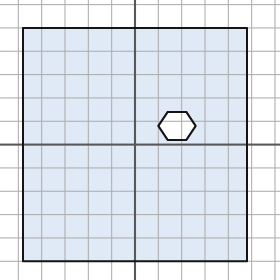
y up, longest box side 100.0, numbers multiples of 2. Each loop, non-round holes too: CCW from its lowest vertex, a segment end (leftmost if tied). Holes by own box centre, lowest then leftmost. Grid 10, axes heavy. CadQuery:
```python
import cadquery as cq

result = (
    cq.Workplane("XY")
    .moveTo(-48.0, -50.0)
    .lineTo(48.0, -50.0)
    .lineTo(48.0, 50.0)
    .lineTo(-48.0, 50.0)
    .close()
    .moveTo(14.0, 2.0)
    .lineTo(22.0, 2.0)
    .lineTo(26.0, 8.0)
    .lineTo(22.0, 14.0)
    .lineTo(14.0, 14.0)
    .lineTo(10.0, 8.0)
    .close()
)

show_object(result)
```